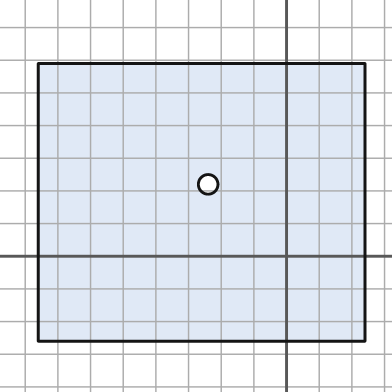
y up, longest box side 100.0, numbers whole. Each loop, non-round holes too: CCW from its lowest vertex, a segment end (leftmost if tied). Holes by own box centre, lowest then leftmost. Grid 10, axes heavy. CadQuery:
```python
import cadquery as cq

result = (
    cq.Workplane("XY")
    .moveTo(-76.0, -26.0)
    .lineTo(24.0, -26.0)
    .lineTo(24.0, 59.0)
    .lineTo(-76.0, 59.0)
    .close()
    .moveTo(-24.0, 22.0)
    .circle(3.0)
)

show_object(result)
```